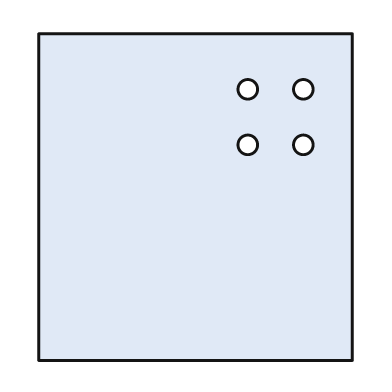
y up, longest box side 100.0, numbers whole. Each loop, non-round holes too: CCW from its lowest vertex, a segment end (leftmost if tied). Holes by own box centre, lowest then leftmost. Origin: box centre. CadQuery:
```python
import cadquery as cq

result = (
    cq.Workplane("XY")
    .moveTo(-48.0, -50.0)
    .lineTo(48.0, -50.0)
    .lineTo(48.0, 50.0)
    .lineTo(-48.0, 50.0)
    .close()
    .moveTo(16.0, 16.0)
    .circle(3.0)
    .moveTo(33.0, 16.0)
    .circle(3.0)
    .moveTo(16.0, 33.0)
    .circle(3.0)
    .moveTo(33.0, 33.0)
    .circle(3.0)
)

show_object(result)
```